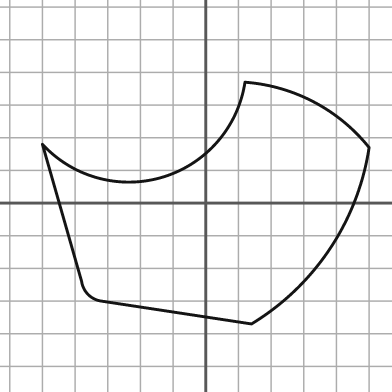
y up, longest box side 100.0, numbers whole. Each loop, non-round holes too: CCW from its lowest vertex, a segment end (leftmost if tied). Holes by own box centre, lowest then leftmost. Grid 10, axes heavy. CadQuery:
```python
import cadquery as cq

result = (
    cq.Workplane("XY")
    .moveTo(14.0, -37.0)
    .threePointArc((38.0, -14.0), (50.0, 17.0))
    .threePointArc((33.0, 31.0), (12.0, 37.0))
    .threePointArc((-13.0, 8.0), (-50.0, 18.0))
    .lineTo(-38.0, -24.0)
    .threePointArc((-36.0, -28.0), (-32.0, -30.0))
    .close()
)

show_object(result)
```